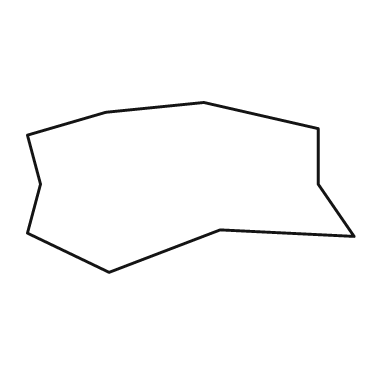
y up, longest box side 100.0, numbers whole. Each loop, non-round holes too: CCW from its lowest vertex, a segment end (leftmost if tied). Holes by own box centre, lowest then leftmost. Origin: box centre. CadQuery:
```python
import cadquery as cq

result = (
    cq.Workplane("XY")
    .moveTo(-25.0, -26.0)
    .lineTo(9.0, -13.0)
    .lineTo(50.0, -15.0)
    .lineTo(39.0, 1.0)
    .lineTo(39.0, 18.0)
    .lineTo(4.0, 26.0)
    .lineTo(-26.0, 23.0)
    .lineTo(-50.0, 16.0)
    .lineTo(-46.0, 1.0)
    .lineTo(-50.0, -14.0)
    .close()
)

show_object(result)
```